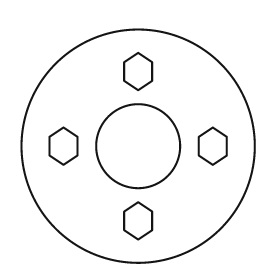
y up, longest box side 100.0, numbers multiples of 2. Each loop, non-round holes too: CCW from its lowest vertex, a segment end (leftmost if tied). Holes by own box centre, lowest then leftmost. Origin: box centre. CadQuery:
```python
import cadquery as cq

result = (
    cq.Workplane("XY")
    .moveTo(0.0, 0.0)
    .circle(50.0)
    .moveTo(0.0, -40.0)
    .lineTo(6.0, -36.0)
    .lineTo(6.0, -28.0)
    .lineTo(0.0, -24.0)
    .lineTo(-6.0, -28.0)
    .lineTo(-6.0, -36.0)
    .close()
    .moveTo(-32.0, -8.0)
    .lineTo(-26.0, -4.0)
    .lineTo(-26.0, 4.0)
    .lineTo(-32.0, 8.0)
    .lineTo(-38.0, 4.0)
    .lineTo(-38.0, -4.0)
    .close()
    .moveTo(0.0, 0.0)
    .circle(18.0)
    .moveTo(32.0, -8.0)
    .lineTo(38.0, -4.0)
    .lineTo(38.0, 4.0)
    .lineTo(32.0, 8.0)
    .lineTo(26.0, 4.0)
    .lineTo(26.0, -4.0)
    .close()
    .moveTo(0.0, 24.0)
    .lineTo(6.0, 28.0)
    .lineTo(6.0, 36.0)
    .lineTo(0.0, 40.0)
    .lineTo(-6.0, 36.0)
    .lineTo(-6.0, 28.0)
    .close()
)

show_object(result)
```